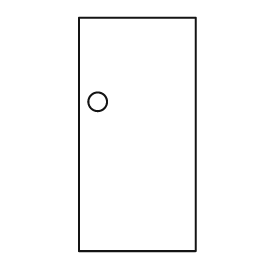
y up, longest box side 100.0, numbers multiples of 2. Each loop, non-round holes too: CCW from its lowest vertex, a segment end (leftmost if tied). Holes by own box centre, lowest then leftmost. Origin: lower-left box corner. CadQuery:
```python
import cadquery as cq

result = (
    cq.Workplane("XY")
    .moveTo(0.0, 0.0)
    .lineTo(50.0, 0.0)
    .lineTo(50.0, 100.0)
    .lineTo(0.0, 100.0)
    .close()
    .moveTo(8.0, 64.0)
    .circle(4.0)
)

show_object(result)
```